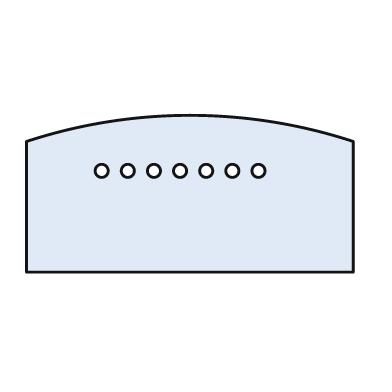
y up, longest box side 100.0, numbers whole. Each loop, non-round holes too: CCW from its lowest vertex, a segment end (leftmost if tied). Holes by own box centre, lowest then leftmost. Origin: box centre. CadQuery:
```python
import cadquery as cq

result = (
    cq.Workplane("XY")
    .moveTo(-50.0, -24.0)
    .lineTo(50.0, -24.0)
    .lineTo(50.0, 16.0)
    .threePointArc((0.0, 24.0), (-50.0, 16.0))
    .close()
    .moveTo(-27.0, 7.0)
    .circle(2.0)
    .moveTo(-19.0, 7.0)
    .circle(2.0)
    .moveTo(-11.0, 7.0)
    .circle(2.0)
    .moveTo(-3.0, 7.0)
    .circle(2.0)
    .moveTo(5.0, 7.0)
    .circle(2.0)
    .moveTo(13.0, 7.0)
    .circle(2.0)
    .moveTo(21.0, 7.0)
    .circle(2.0)
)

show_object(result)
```